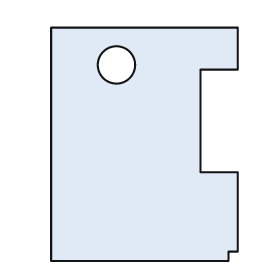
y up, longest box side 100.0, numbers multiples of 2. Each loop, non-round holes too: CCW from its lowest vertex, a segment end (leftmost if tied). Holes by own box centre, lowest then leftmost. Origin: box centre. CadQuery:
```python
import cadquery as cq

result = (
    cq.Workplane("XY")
    .moveTo(-40.0, -50.0)
    .lineTo(36.0, -50.0)
    .lineTo(36.0, -46.0)
    .lineTo(40.0, -46.0)
    .lineTo(40.0, -12.0)
    .lineTo(24.0, -12.0)
    .lineTo(24.0, 32.0)
    .lineTo(40.0, 32.0)
    .lineTo(40.0, 50.0)
    .lineTo(-40.0, 50.0)
    .close()
    .moveTo(-12.0, 34.0)
    .circle(8.0)
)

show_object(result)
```